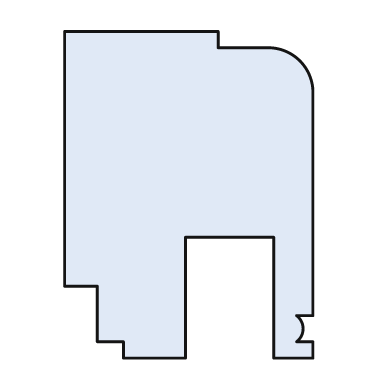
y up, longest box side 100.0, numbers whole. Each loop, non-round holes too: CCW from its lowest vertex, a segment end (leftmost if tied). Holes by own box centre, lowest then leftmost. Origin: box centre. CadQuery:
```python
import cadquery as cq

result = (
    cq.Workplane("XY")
    .moveTo(-20.0, -50.0)
    .lineTo(-1.0, -50.0)
    .lineTo(-1.0, -13.0)
    .lineTo(26.0, -13.0)
    .lineTo(26.0, -50.0)
    .lineTo(38.0, -50.0)
    .lineTo(38.0, -45.0)
    .lineTo(33.0, -45.0)
    .threePointArc((35.0, -41.0), (33.0, -37.0))
    .lineTo(38.0, -37.0)
    .lineTo(38.0, 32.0)
    .threePointArc((34.0, 41.0), (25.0, 45.0))
    .lineTo(9.0, 45.0)
    .lineTo(9.0, 50.0)
    .lineTo(-38.0, 50.0)
    .lineTo(-38.0, -28.0)
    .lineTo(-28.0, -28.0)
    .lineTo(-28.0, -45.0)
    .lineTo(-20.0, -45.0)
    .close()
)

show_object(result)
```